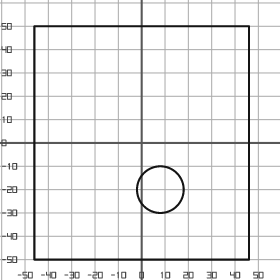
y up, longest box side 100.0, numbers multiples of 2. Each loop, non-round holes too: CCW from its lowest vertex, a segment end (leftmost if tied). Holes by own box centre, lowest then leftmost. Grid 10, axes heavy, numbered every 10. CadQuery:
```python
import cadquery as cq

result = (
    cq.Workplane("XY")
    .moveTo(-46.0, -50.0)
    .lineTo(46.0, -50.0)
    .lineTo(46.0, 50.0)
    .lineTo(-46.0, 50.0)
    .close()
    .moveTo(8.0, -20.0)
    .circle(10.0)
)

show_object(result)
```